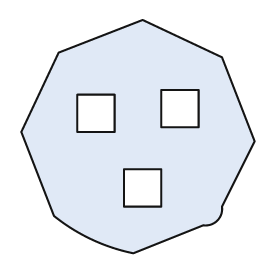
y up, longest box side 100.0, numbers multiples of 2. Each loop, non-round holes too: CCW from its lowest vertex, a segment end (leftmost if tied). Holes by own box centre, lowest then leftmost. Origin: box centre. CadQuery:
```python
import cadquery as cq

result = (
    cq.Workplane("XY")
    .moveTo(-2.0, -50.0)
    .lineTo(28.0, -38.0)
    .threePointArc((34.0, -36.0), (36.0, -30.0))
    .lineTo(50.0, -2.0)
    .lineTo(36.0, 34.0)
    .lineTo(2.0, 50.0)
    .lineTo(-34.0, 36.0)
    .lineTo(-50.0, 2.0)
    .lineTo(-36.0, -34.0)
    .threePointArc((-20.0, -44.0), (-2.0, -50.0))
    .close()
    .moveTo(-6.0, -30.0)
    .lineTo(10.0, -30.0)
    .lineTo(10.0, -14.0)
    .lineTo(-6.0, -14.0)
    .close()
    .moveTo(-26.0, 2.0)
    .lineTo(-10.0, 2.0)
    .lineTo(-10.0, 18.0)
    .lineTo(-26.0, 18.0)
    .close()
    .moveTo(10.0, 4.0)
    .lineTo(26.0, 4.0)
    .lineTo(26.0, 20.0)
    .lineTo(10.0, 20.0)
    .close()
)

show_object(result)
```